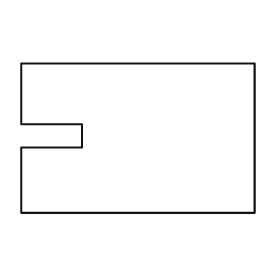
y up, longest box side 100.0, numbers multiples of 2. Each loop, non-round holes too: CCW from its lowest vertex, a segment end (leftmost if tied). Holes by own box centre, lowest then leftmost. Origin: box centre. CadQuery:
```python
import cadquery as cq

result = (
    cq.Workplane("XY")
    .moveTo(-50.0, -32.0)
    .lineTo(50.0, -32.0)
    .lineTo(50.0, 32.0)
    .lineTo(-50.0, 32.0)
    .lineTo(-50.0, 6.0)
    .lineTo(-24.0, 6.0)
    .lineTo(-24.0, -4.0)
    .lineTo(-50.0, -4.0)
    .close()
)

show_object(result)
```